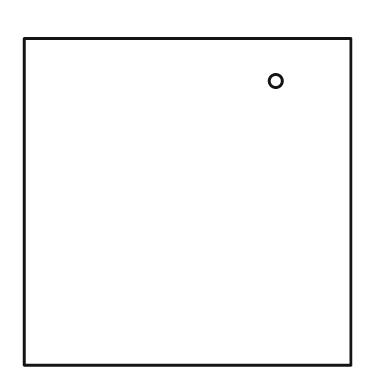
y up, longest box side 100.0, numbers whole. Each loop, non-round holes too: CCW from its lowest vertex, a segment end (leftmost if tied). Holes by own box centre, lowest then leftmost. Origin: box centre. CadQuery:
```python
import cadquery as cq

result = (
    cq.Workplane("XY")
    .moveTo(-50.0, -50.0)
    .lineTo(50.0, -50.0)
    .lineTo(50.0, 50.0)
    .lineTo(-50.0, 50.0)
    .close()
    .moveTo(27.0, 37.0)
    .circle(2.0)
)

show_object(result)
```